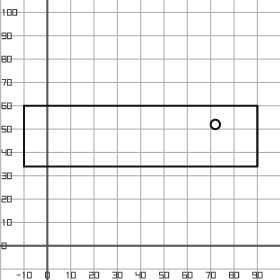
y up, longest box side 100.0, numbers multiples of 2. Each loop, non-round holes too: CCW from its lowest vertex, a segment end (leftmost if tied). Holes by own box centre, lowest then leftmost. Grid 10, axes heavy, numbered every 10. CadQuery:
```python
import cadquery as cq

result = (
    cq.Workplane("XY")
    .moveTo(-10.0, 34.0)
    .lineTo(90.0, 34.0)
    .lineTo(90.0, 60.0)
    .lineTo(-10.0, 60.0)
    .close()
    .moveTo(72.0, 52.0)
    .circle(2.0)
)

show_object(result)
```